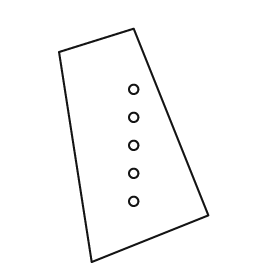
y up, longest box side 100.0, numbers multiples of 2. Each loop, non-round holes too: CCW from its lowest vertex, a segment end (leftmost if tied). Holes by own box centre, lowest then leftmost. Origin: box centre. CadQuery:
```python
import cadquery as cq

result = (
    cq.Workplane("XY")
    .moveTo(-18.0, -50.0)
    .lineTo(32.0, -30.0)
    .lineTo(0.0, 50.0)
    .lineTo(-32.0, 40.0)
    .close()
    .moveTo(0.0, -24.0)
    .circle(2.0)
    .moveTo(0.0, -12.0)
    .circle(2.0)
    .moveTo(0.0, 0.0)
    .circle(2.0)
    .moveTo(0.0, 12.0)
    .circle(2.0)
    .moveTo(0.0, 24.0)
    .circle(2.0)
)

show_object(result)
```